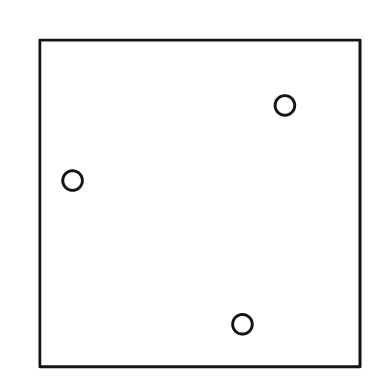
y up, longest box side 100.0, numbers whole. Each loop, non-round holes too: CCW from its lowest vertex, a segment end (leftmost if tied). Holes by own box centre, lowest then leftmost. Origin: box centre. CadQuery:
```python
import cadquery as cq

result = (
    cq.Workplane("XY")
    .moveTo(-49.0, -50.0)
    .lineTo(49.0, -50.0)
    .lineTo(49.0, 50.0)
    .lineTo(-49.0, 50.0)
    .close()
    .moveTo(13.0, -37.0)
    .circle(3.0)
    .moveTo(-39.0, 7.0)
    .circle(3.0)
    .moveTo(26.0, 30.0)
    .circle(3.0)
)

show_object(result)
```